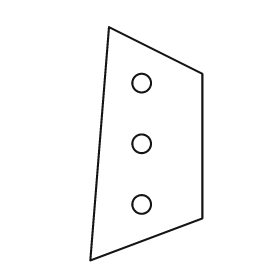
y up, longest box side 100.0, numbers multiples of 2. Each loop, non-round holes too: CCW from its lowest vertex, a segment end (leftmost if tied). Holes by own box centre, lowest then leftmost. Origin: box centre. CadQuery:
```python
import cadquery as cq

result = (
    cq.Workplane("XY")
    .moveTo(-24.0, -50.0)
    .lineTo(24.0, -32.0)
    .lineTo(24.0, 30.0)
    .lineTo(-16.0, 50.0)
    .close()
    .moveTo(-2.0, -26.0)
    .circle(4.0)
    .moveTo(-2.0, 0.0)
    .circle(4.0)
    .moveTo(-2.0, 26.0)
    .circle(4.0)
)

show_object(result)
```